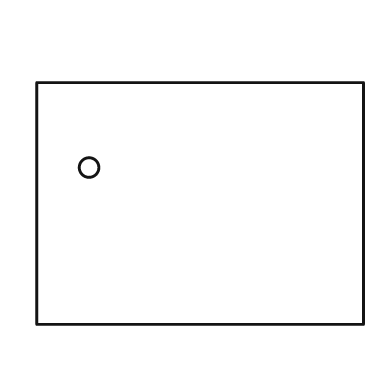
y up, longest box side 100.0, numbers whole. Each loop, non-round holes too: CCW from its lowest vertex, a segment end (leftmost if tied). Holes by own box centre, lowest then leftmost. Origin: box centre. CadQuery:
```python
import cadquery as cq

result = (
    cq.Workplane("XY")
    .moveTo(-50.0, -37.0)
    .lineTo(50.0, -37.0)
    .lineTo(50.0, 37.0)
    .lineTo(-50.0, 37.0)
    .close()
    .moveTo(-34.0, 11.0)
    .circle(3.0)
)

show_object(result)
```